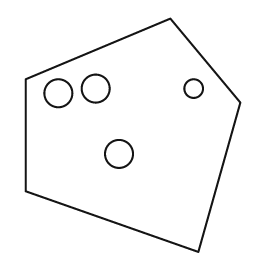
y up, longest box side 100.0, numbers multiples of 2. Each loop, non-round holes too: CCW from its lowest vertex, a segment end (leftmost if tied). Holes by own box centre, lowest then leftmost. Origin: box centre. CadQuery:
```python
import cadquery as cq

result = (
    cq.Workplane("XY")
    .moveTo(28.0, -50.0)
    .lineTo(46.0, 14.0)
    .lineTo(16.0, 50.0)
    .lineTo(-46.0, 24.0)
    .lineTo(-46.0, -24.0)
    .close()
    .moveTo(-6.0, -8.0)
    .circle(6.0)
    .moveTo(-32.0, 18.0)
    .circle(6.0)
    .moveTo(-16.0, 20.0)
    .circle(6.0)
    .moveTo(26.0, 20.0)
    .circle(4.0)
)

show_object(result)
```